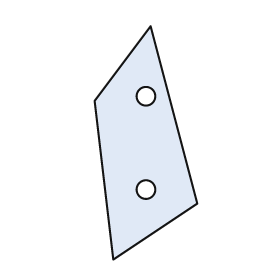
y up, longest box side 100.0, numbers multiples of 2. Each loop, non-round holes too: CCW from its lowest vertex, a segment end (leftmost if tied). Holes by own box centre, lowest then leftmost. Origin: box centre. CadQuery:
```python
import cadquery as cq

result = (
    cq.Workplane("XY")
    .moveTo(-14.0, -50.0)
    .lineTo(22.0, -26.0)
    .lineTo(2.0, 50.0)
    .lineTo(-22.0, 18.0)
    .close()
    .moveTo(0.0, -20.0)
    .circle(4.0)
    .moveTo(0.0, 20.0)
    .circle(4.0)
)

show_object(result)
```